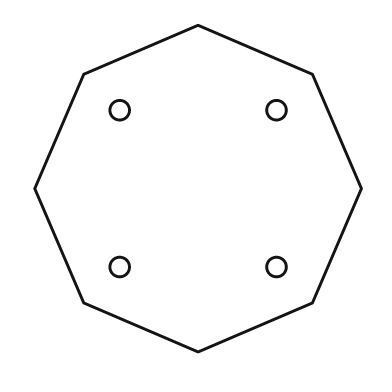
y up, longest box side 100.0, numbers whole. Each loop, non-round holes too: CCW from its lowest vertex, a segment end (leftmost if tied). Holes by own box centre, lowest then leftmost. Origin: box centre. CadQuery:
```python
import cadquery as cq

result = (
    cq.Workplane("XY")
    .moveTo(0.0, -50.0)
    .lineTo(35.0, -35.0)
    .lineTo(50.0, 0.0)
    .lineTo(35.0, 35.0)
    .lineTo(0.0, 50.0)
    .lineTo(-35.0, 35.0)
    .lineTo(-50.0, 0.0)
    .lineTo(-35.0, -35.0)
    .close()
    .moveTo(-24.0, -24.0)
    .circle(3.0)
    .moveTo(24.0, -24.0)
    .circle(3.0)
    .moveTo(-24.0, 24.0)
    .circle(3.0)
    .moveTo(24.0, 24.0)
    .circle(3.0)
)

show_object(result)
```